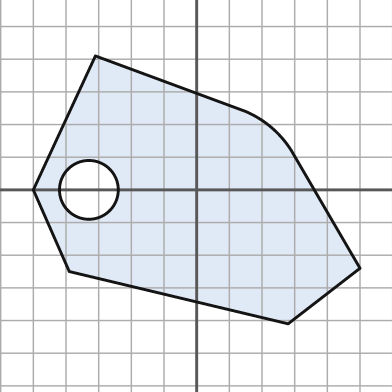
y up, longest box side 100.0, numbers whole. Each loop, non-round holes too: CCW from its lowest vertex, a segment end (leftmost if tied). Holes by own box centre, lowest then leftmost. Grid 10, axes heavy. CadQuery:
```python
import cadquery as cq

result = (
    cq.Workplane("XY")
    .moveTo(28.0, -41.0)
    .lineTo(50.0, -24.0)
    .lineTo(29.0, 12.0)
    .threePointArc((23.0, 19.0), (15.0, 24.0))
    .lineTo(-31.0, 41.0)
    .lineTo(-50.0, 0.0)
    .lineTo(-39.0, -25.0)
    .close()
    .moveTo(-33.0, 0.0)
    .circle(9.0)
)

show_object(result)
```